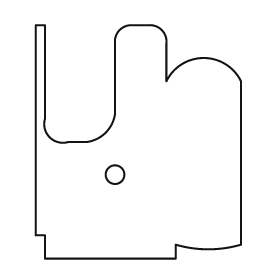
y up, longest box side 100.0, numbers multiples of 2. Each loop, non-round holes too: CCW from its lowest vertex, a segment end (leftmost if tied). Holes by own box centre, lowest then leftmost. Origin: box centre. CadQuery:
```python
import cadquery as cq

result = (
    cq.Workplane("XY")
    .moveTo(-40.0, -50.0)
    .lineTo(16.0, -50.0)
    .lineTo(16.0, -44.0)
    .threePointArc((30.0, -46.0), (44.0, -44.0))
    .lineTo(44.0, 26.0)
    .threePointArc((28.0, 36.0), (12.0, 26.0))
    .lineTo(12.0, 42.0)
    .threePointArc((10.0, 48.0), (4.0, 50.0))
    .lineTo(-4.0, 50.0)
    .threePointArc((-8.0, 48.0), (-10.0, 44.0))
    .lineTo(-10.0, 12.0)
    .threePointArc((-14.0, 4.0), (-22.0, 0.0))
    .lineTo(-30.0, 0.0)
    .threePointArc((-38.0, 2.0), (-40.0, 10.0))
    .lineTo(-40.0, 50.0)
    .lineTo(-44.0, 50.0)
    .lineTo(-44.0, -40.0)
    .lineTo(-40.0, -40.0)
    .close()
    .moveTo(-10.0, -14.0)
    .circle(4.0)
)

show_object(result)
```